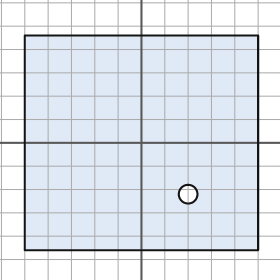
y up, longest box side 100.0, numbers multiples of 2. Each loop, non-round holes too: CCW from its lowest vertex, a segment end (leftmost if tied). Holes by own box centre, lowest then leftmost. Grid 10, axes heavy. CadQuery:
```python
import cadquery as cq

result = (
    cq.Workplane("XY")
    .moveTo(-50.0, -46.0)
    .lineTo(50.0, -46.0)
    .lineTo(50.0, 46.0)
    .lineTo(-50.0, 46.0)
    .close()
    .moveTo(20.0, -22.0)
    .circle(4.0)
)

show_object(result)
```